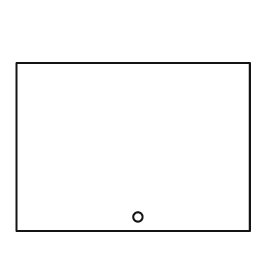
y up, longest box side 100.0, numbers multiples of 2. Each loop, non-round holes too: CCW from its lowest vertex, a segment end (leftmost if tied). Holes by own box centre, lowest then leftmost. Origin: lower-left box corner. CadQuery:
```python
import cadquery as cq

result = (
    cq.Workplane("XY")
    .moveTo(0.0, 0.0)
    .lineTo(100.0, 0.0)
    .lineTo(100.0, 72.0)
    .lineTo(0.0, 72.0)
    .close()
    .moveTo(52.0, 6.0)
    .circle(2.0)
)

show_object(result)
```